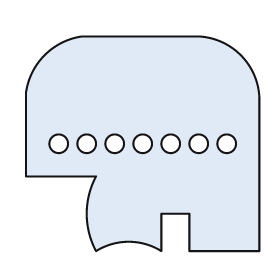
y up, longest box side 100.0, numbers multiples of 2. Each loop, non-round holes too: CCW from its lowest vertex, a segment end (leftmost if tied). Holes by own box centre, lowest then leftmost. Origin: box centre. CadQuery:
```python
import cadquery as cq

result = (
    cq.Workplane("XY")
    .moveTo(-20.0, -46.0)
    .threePointArc((-6.0, -42.0), (8.0, -46.0))
    .lineTo(8.0, -30.0)
    .lineTo(20.0, -30.0)
    .lineTo(20.0, -46.0)
    .lineTo(50.0, -46.0)
    .lineTo(50.0, 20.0)
    .threePointArc((42.0, 38.0), (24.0, 46.0))
    .lineTo(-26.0, 46.0)
    .threePointArc((-42.0, 38.0), (-50.0, 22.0))
    .lineTo(-50.0, -14.0)
    .lineTo(-20.0, -14.0)
    .threePointArc((-24.0, -30.0), (-20.0, -46.0))
    .close()
    .moveTo(-36.0, 0.0)
    .circle(4.0)
    .moveTo(-24.0, 0.0)
    .circle(4.0)
    .moveTo(-12.0, 0.0)
    .circle(4.0)
    .moveTo(0.0, 0.0)
    .circle(4.0)
    .moveTo(12.0, 0.0)
    .circle(4.0)
    .moveTo(24.0, 0.0)
    .circle(4.0)
    .moveTo(36.0, 0.0)
    .circle(4.0)
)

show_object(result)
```